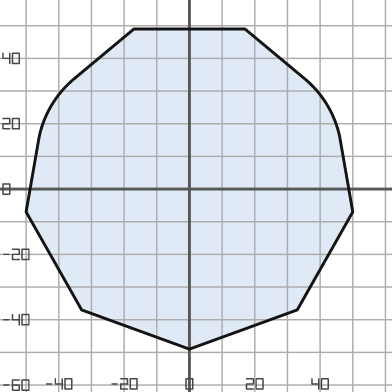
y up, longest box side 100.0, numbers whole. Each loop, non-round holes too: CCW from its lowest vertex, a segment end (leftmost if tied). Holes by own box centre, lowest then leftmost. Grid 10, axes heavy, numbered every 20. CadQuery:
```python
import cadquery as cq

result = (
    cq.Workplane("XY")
    .moveTo(0.0, -49.0)
    .lineTo(33.0, -37.0)
    .lineTo(50.0, -7.0)
    .lineTo(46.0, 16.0)
    .threePointArc((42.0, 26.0), (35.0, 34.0))
    .lineTo(17.0, 49.0)
    .lineTo(-17.0, 49.0)
    .lineTo(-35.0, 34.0)
    .threePointArc((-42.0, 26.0), (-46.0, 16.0))
    .lineTo(-50.0, -7.0)
    .lineTo(-33.0, -37.0)
    .close()
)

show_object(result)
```